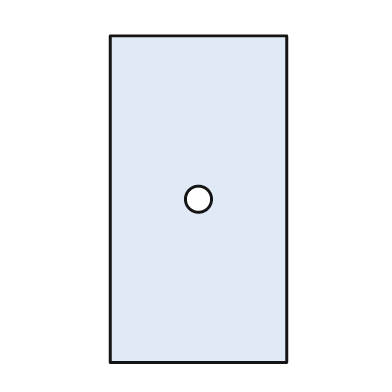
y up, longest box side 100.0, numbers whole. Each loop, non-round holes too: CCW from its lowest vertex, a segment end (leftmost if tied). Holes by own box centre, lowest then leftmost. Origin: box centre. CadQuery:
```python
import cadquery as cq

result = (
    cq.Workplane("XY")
    .moveTo(-27.0, -50.0)
    .lineTo(27.0, -50.0)
    .lineTo(27.0, 50.0)
    .lineTo(-27.0, 50.0)
    .close()
    .moveTo(0.0, 0.0)
    .circle(4.0)
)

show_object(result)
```